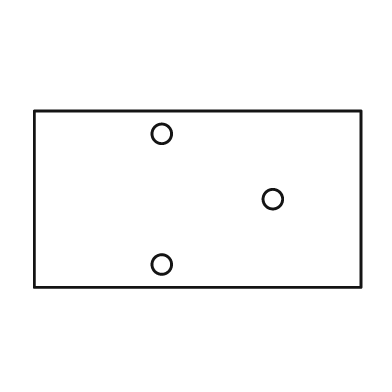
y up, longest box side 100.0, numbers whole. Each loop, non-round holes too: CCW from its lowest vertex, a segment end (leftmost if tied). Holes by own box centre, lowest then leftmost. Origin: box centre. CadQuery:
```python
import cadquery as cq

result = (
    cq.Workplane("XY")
    .moveTo(-50.0, -27.0)
    .lineTo(50.0, -27.0)
    .lineTo(50.0, 27.0)
    .lineTo(-50.0, 27.0)
    .close()
    .moveTo(-11.0, -20.0)
    .circle(3.0)
    .moveTo(23.0, 0.0)
    .circle(3.0)
    .moveTo(-11.0, 20.0)
    .circle(3.0)
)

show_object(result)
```